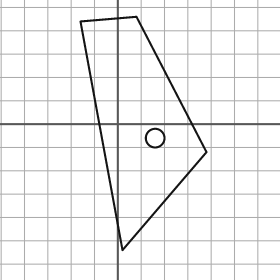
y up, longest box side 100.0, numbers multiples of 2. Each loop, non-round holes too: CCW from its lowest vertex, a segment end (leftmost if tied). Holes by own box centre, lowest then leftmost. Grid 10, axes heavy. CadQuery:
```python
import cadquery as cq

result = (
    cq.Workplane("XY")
    .moveTo(2.0, -54.0)
    .lineTo(38.0, -12.0)
    .lineTo(8.0, 46.0)
    .lineTo(-16.0, 44.0)
    .close()
    .moveTo(16.0, -6.0)
    .circle(4.0)
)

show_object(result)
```